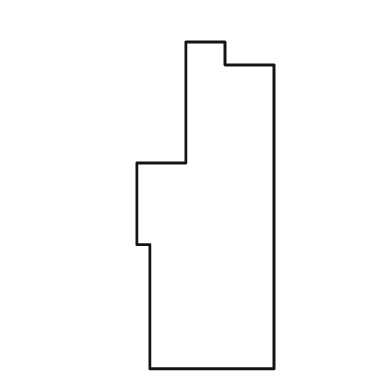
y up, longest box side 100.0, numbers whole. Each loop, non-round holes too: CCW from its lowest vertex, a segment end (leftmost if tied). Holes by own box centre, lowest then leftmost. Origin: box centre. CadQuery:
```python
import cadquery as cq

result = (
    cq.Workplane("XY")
    .moveTo(-17.0, -50.0)
    .lineTo(21.0, -50.0)
    .lineTo(21.0, 43.0)
    .lineTo(6.0, 43.0)
    .lineTo(6.0, 50.0)
    .lineTo(-6.0, 50.0)
    .lineTo(-6.0, 13.0)
    .lineTo(-21.0, 13.0)
    .lineTo(-21.0, -12.0)
    .lineTo(-17.0, -12.0)
    .close()
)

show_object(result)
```